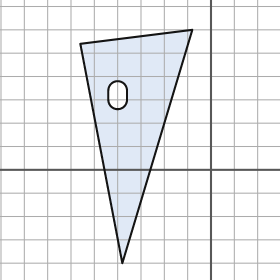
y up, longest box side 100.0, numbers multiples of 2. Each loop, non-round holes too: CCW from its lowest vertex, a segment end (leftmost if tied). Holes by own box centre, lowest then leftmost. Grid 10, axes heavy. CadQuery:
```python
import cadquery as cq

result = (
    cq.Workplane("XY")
    .moveTo(-38.0, -40.0)
    .lineTo(-8.0, 60.0)
    .lineTo(-56.0, 54.0)
    .close()
    .moveTo(-44.0, 30.0)
    .threePointArc((-40.0, 26.0), (-36.0, 30.0))
    .lineTo(-36.0, 34.0)
    .threePointArc((-40.0, 38.0), (-44.0, 34.0))
    .close()
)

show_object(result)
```